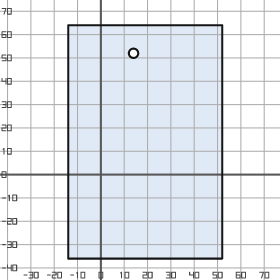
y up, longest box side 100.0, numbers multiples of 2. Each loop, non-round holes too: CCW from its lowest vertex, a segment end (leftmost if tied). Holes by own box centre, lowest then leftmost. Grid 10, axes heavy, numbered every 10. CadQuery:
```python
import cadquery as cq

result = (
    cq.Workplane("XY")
    .moveTo(-14.0, -36.0)
    .lineTo(52.0, -36.0)
    .lineTo(52.0, 64.0)
    .lineTo(-14.0, 64.0)
    .close()
    .moveTo(14.0, 52.0)
    .circle(2.0)
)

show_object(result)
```